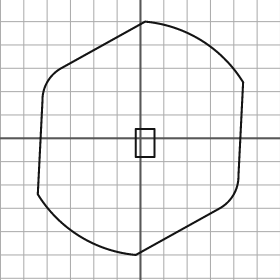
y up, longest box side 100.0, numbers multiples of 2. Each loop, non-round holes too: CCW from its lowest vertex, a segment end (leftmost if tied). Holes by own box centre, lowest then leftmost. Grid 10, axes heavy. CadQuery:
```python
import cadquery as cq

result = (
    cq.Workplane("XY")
    .moveTo(-2.0, -50.0)
    .lineTo(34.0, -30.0)
    .threePointArc((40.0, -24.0), (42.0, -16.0))
    .lineTo(44.0, 24.0)
    .threePointArc((26.0, 42.0), (2.0, 50.0))
    .lineTo(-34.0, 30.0)
    .threePointArc((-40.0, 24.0), (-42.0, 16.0))
    .lineTo(-44.0, -24.0)
    .threePointArc((-26.0, -42.0), (-2.0, -50.0))
    .close()
    .moveTo(-2.0, -8.0)
    .lineTo(6.0, -8.0)
    .lineTo(6.0, 4.0)
    .lineTo(-2.0, 4.0)
    .close()
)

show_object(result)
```